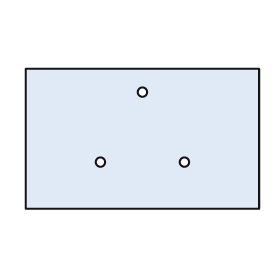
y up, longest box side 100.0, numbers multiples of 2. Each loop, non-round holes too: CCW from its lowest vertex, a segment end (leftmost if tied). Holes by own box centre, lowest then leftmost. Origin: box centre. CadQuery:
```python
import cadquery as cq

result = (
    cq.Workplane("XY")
    .moveTo(-50.0, -30.0)
    .lineTo(50.0, -30.0)
    .lineTo(50.0, 30.0)
    .lineTo(-50.0, 30.0)
    .close()
    .moveTo(-18.0, -10.0)
    .circle(2.0)
    .moveTo(18.0, -10.0)
    .circle(2.0)
    .moveTo(0.0, 20.0)
    .circle(2.0)
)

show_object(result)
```